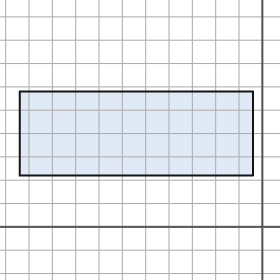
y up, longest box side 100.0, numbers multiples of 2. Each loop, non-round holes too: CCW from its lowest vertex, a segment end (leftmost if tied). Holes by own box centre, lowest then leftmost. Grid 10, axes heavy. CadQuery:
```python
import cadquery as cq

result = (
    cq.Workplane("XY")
    .moveTo(-104.0, 22.0)
    .lineTo(-4.0, 22.0)
    .lineTo(-4.0, 58.0)
    .lineTo(-104.0, 58.0)
    .close()
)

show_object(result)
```